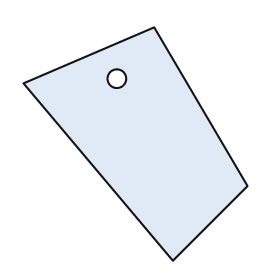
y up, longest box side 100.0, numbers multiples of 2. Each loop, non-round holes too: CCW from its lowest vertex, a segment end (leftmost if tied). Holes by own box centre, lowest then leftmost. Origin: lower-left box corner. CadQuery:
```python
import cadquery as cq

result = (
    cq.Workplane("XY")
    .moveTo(64.0, 0.0)
    .lineTo(96.0, 32.0)
    .lineTo(56.0, 100.0)
    .lineTo(0.0, 76.0)
    .close()
    .moveTo(40.0, 78.0)
    .circle(4.0)
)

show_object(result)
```